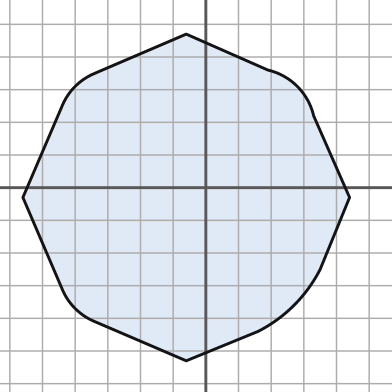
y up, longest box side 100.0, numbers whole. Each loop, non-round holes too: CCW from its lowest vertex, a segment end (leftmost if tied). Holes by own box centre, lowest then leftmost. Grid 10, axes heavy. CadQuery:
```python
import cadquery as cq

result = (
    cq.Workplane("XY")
    .moveTo(-6.0, -53.0)
    .lineTo(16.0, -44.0)
    .threePointArc((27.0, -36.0), (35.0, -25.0))
    .lineTo(44.0, -3.0)
    .lineTo(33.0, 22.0)
    .threePointArc((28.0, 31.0), (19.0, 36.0))
    .lineTo(-6.0, 47.0)
    .lineTo(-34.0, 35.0)
    .threePointArc((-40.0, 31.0), (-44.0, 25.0))
    .lineTo(-56.0, -3.0)
    .lineTo(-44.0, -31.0)
    .threePointArc((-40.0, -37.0), (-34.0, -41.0))
    .close()
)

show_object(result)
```